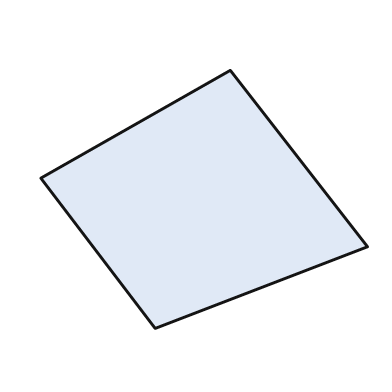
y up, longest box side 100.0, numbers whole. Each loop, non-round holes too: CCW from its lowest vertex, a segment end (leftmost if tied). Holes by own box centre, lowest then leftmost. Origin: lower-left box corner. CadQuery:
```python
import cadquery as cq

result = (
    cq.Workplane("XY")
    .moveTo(35.0, 0.0)
    .lineTo(100.0, 25.0)
    .lineTo(58.0, 79.0)
    .lineTo(0.0, 46.0)
    .close()
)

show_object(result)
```